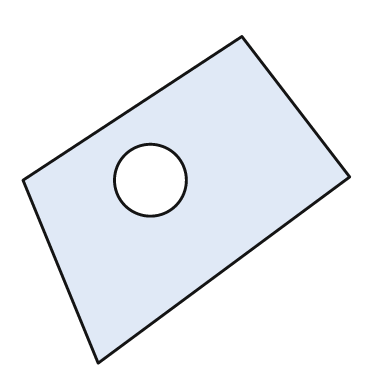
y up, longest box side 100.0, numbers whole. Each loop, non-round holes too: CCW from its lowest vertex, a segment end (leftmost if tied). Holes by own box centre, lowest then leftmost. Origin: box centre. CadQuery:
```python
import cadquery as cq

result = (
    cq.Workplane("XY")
    .moveTo(-27.0, -50.0)
    .lineTo(50.0, 7.0)
    .lineTo(17.0, 50.0)
    .lineTo(-50.0, 6.0)
    .close()
    .moveTo(-11.0, 6.0)
    .circle(11.0)
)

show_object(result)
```